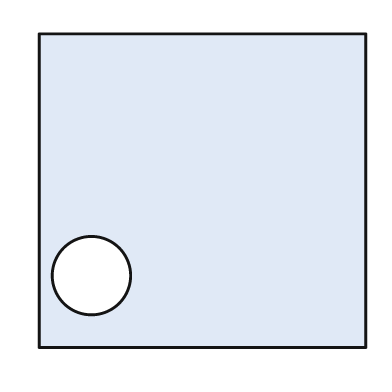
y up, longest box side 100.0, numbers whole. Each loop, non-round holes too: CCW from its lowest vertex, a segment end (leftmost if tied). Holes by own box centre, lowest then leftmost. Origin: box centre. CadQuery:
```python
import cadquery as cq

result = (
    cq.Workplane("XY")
    .moveTo(-50.0, -48.0)
    .lineTo(50.0, -48.0)
    .lineTo(50.0, 48.0)
    .lineTo(-50.0, 48.0)
    .close()
    .moveTo(-34.0, -26.0)
    .circle(12.0)
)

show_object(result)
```